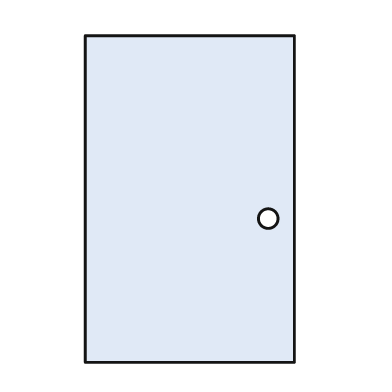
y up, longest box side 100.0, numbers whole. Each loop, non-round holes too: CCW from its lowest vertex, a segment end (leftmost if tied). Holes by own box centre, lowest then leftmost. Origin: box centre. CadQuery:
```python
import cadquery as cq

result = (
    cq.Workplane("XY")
    .moveTo(-32.0, -50.0)
    .lineTo(32.0, -50.0)
    .lineTo(32.0, 50.0)
    .lineTo(-32.0, 50.0)
    .close()
    .moveTo(24.0, -6.0)
    .circle(3.0)
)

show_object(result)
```